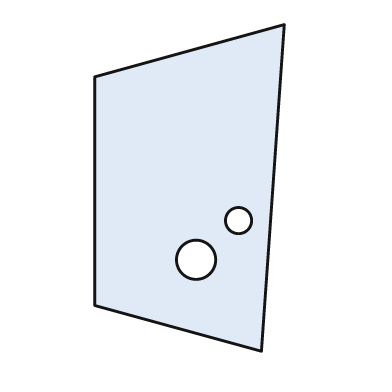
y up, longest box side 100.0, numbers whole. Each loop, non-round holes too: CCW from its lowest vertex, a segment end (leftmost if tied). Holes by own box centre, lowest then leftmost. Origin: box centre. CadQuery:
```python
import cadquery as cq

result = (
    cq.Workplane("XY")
    .moveTo(22.0, -50.0)
    .lineTo(29.0, 50.0)
    .lineTo(-29.0, 34.0)
    .lineTo(-29.0, -36.0)
    .close()
    .moveTo(2.0, -22.0)
    .circle(6.0)
    .moveTo(15.0, -10.0)
    .circle(4.0)
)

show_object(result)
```